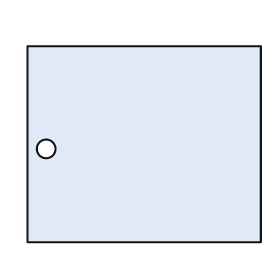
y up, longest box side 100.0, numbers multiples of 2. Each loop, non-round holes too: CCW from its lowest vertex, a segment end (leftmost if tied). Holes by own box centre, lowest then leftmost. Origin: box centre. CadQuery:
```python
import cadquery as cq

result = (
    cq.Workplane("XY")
    .moveTo(-50.0, -42.0)
    .lineTo(50.0, -42.0)
    .lineTo(50.0, 42.0)
    .lineTo(-50.0, 42.0)
    .close()
    .moveTo(-42.0, -2.0)
    .circle(4.0)
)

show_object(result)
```